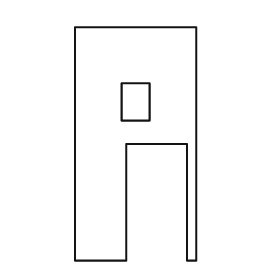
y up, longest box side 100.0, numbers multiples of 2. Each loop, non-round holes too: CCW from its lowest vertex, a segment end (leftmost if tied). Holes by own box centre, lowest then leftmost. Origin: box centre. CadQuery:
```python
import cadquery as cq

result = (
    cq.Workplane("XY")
    .moveTo(-26.0, -50.0)
    .lineTo(-4.0, -50.0)
    .lineTo(-4.0, 0.0)
    .lineTo(22.0, 0.0)
    .lineTo(22.0, -50.0)
    .lineTo(26.0, -50.0)
    .lineTo(26.0, 50.0)
    .lineTo(-26.0, 50.0)
    .close()
    .moveTo(-6.0, 10.0)
    .lineTo(6.0, 10.0)
    .lineTo(6.0, 26.0)
    .lineTo(-6.0, 26.0)
    .close()
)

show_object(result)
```